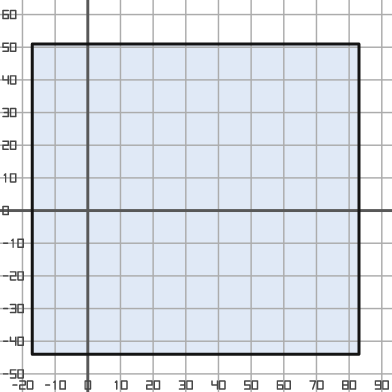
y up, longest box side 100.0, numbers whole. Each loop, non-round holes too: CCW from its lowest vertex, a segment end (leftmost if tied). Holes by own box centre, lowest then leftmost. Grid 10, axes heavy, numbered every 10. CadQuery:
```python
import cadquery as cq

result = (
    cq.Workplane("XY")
    .moveTo(-17.0, -44.0)
    .lineTo(83.0, -44.0)
    .lineTo(83.0, 51.0)
    .lineTo(-17.0, 51.0)
    .close()
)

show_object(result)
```